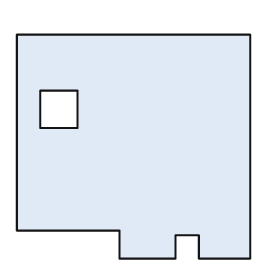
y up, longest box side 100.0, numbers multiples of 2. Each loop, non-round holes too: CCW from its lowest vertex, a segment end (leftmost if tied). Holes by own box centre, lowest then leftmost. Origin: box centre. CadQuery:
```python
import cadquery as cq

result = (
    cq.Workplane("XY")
    .moveTo(-6.0, -48.0)
    .lineTo(18.0, -48.0)
    .lineTo(18.0, -38.0)
    .lineTo(28.0, -38.0)
    .lineTo(28.0, -48.0)
    .lineTo(50.0, -48.0)
    .lineTo(50.0, 48.0)
    .lineTo(-50.0, 48.0)
    .lineTo(-50.0, -36.0)
    .lineTo(-6.0, -36.0)
    .close()
    .moveTo(-40.0, 8.0)
    .lineTo(-24.0, 8.0)
    .lineTo(-24.0, 24.0)
    .lineTo(-40.0, 24.0)
    .close()
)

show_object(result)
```